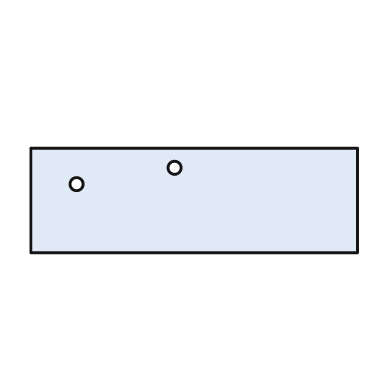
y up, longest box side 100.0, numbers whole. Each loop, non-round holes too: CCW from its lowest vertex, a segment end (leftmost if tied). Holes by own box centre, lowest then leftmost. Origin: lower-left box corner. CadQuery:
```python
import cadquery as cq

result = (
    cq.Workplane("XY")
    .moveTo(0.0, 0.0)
    .lineTo(100.0, 0.0)
    .lineTo(100.0, 32.0)
    .lineTo(0.0, 32.0)
    .close()
    .moveTo(14.0, 21.0)
    .circle(2.0)
    .moveTo(44.0, 26.0)
    .circle(2.0)
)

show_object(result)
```